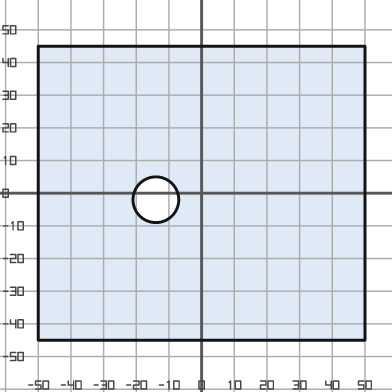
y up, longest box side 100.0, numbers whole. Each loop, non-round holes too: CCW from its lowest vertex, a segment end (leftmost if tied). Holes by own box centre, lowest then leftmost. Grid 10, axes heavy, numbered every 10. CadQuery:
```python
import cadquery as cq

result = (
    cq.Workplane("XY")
    .moveTo(-50.0, -45.0)
    .lineTo(50.0, -45.0)
    .lineTo(50.0, 45.0)
    .lineTo(-50.0, 45.0)
    .close()
    .moveTo(-14.0, -2.0)
    .circle(7.0)
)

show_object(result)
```